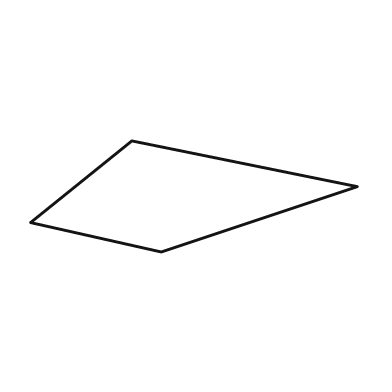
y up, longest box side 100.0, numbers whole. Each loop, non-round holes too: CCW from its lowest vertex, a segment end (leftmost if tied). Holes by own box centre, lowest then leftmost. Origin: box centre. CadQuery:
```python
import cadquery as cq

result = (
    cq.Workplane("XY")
    .moveTo(-10.0, -17.0)
    .lineTo(50.0, 3.0)
    .lineTo(-19.0, 17.0)
    .lineTo(-50.0, -8.0)
    .close()
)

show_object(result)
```